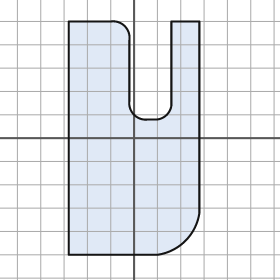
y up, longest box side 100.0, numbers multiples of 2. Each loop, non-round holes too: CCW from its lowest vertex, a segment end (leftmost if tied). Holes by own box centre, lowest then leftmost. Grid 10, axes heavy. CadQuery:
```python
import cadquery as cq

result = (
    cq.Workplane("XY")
    .moveTo(-28.0, -50.0)
    .lineTo(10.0, -50.0)
    .threePointArc((22.0, -44.0), (28.0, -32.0))
    .lineTo(28.0, 50.0)
    .lineTo(16.0, 50.0)
    .lineTo(16.0, 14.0)
    .threePointArc((14.0, 10.0), (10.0, 8.0))
    .lineTo(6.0, 8.0)
    .threePointArc((0.0, 10.0), (-2.0, 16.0))
    .lineTo(-2.0, 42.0)
    .threePointArc((-4.0, 48.0), (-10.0, 50.0))
    .lineTo(-28.0, 50.0)
    .close()
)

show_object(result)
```